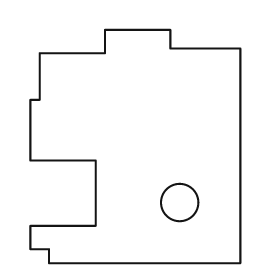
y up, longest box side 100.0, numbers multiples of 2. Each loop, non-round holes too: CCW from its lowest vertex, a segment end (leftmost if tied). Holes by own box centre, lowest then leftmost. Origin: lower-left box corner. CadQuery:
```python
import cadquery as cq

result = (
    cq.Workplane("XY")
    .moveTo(8.0, 0.0)
    .lineTo(90.0, 0.0)
    .lineTo(90.0, 92.0)
    .lineTo(60.0, 92.0)
    .lineTo(60.0, 100.0)
    .lineTo(32.0, 100.0)
    .lineTo(32.0, 90.0)
    .lineTo(4.0, 90.0)
    .lineTo(4.0, 70.0)
    .lineTo(0.0, 70.0)
    .lineTo(0.0, 44.0)
    .lineTo(28.0, 44.0)
    .lineTo(28.0, 16.0)
    .lineTo(0.0, 16.0)
    .lineTo(0.0, 6.0)
    .lineTo(8.0, 6.0)
    .close()
    .moveTo(64.0, 26.0)
    .circle(8.0)
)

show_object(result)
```